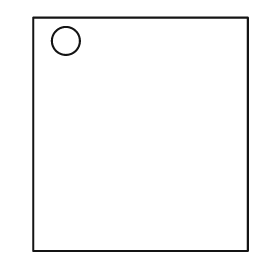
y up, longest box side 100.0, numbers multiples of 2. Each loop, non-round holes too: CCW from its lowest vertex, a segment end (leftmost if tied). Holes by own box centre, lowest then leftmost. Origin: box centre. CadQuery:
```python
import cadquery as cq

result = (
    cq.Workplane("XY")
    .moveTo(-46.0, -50.0)
    .lineTo(46.0, -50.0)
    .lineTo(46.0, 50.0)
    .lineTo(-46.0, 50.0)
    .close()
    .moveTo(-32.0, 40.0)
    .circle(6.0)
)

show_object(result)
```